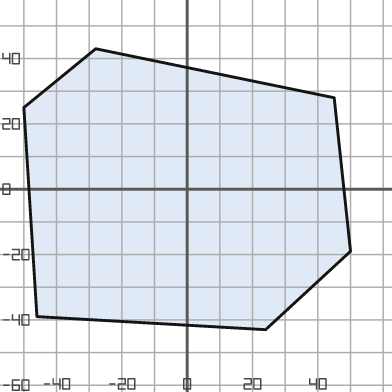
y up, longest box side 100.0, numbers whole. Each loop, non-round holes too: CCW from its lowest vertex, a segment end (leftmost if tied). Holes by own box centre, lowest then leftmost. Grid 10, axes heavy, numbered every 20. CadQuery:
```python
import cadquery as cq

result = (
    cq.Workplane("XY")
    .moveTo(24.0, -43.0)
    .lineTo(50.0, -19.0)
    .lineTo(45.0, 28.0)
    .lineTo(-28.0, 43.0)
    .lineTo(-50.0, 25.0)
    .lineTo(-46.0, -39.0)
    .close()
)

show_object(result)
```